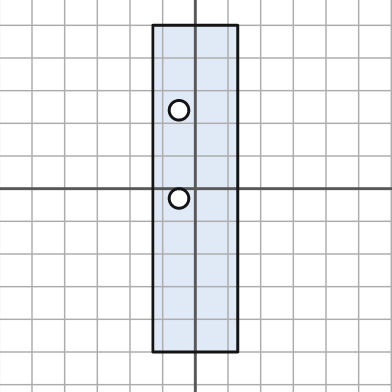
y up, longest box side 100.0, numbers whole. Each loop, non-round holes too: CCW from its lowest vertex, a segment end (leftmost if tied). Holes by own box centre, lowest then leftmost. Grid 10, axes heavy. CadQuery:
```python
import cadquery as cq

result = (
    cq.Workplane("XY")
    .moveTo(-13.0, -50.0)
    .lineTo(13.0, -50.0)
    .lineTo(13.0, 50.0)
    .lineTo(-13.0, 50.0)
    .close()
    .moveTo(-5.0, -3.0)
    .circle(3.0)
    .moveTo(-5.0, 24.0)
    .circle(3.0)
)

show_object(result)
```